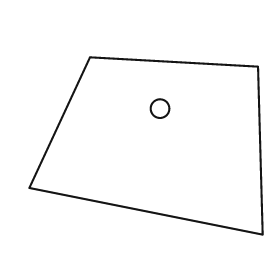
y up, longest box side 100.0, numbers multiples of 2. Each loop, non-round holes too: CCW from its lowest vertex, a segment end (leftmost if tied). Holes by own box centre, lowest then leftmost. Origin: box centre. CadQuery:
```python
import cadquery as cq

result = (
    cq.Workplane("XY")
    .moveTo(50.0, -38.0)
    .lineTo(48.0, 34.0)
    .lineTo(-24.0, 38.0)
    .lineTo(-50.0, -18.0)
    .close()
    .moveTo(6.0, 16.0)
    .circle(4.0)
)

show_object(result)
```